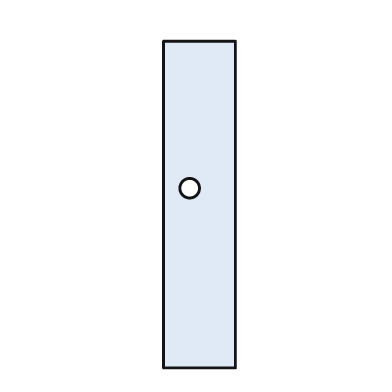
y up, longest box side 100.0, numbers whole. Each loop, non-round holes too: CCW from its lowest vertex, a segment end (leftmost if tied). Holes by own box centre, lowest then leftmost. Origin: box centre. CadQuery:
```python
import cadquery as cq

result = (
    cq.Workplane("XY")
    .moveTo(-11.0, -50.0)
    .lineTo(11.0, -50.0)
    .lineTo(11.0, 50.0)
    .lineTo(-11.0, 50.0)
    .close()
    .moveTo(-3.0, 5.0)
    .circle(3.0)
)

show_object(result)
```